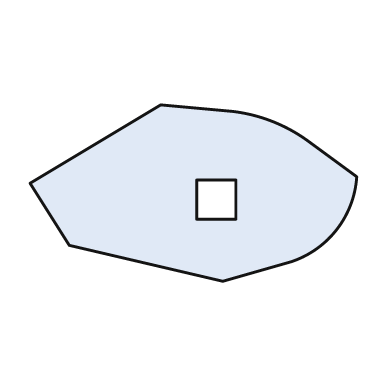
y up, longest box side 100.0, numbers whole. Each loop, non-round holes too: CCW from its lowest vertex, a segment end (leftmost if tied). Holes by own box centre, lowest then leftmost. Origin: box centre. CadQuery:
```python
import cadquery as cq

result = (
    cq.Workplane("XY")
    .moveTo(9.0, -27.0)
    .lineTo(30.0, -21.0)
    .threePointArc((44.0, -11.0), (50.0, 5.0))
    .lineTo(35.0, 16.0)
    .threePointArc((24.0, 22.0), (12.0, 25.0))
    .lineTo(-10.0, 27.0)
    .lineTo(-50.0, 3.0)
    .lineTo(-38.0, -16.0)
    .close()
    .moveTo(1.0, -8.0)
    .lineTo(13.0, -8.0)
    .lineTo(13.0, 4.0)
    .lineTo(1.0, 4.0)
    .close()
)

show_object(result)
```